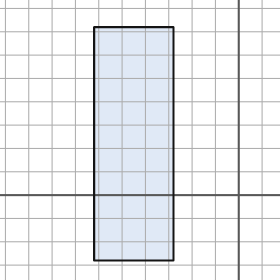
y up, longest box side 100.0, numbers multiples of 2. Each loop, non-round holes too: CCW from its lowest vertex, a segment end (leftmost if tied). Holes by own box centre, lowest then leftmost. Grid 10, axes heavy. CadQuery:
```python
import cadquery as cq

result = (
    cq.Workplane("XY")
    .moveTo(-62.0, -28.0)
    .lineTo(-28.0, -28.0)
    .lineTo(-28.0, 72.0)
    .lineTo(-62.0, 72.0)
    .close()
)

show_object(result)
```